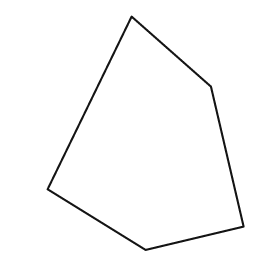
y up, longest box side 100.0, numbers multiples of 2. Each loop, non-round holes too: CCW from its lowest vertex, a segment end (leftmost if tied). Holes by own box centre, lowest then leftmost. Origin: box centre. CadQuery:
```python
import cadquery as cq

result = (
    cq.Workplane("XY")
    .moveTo(0.0, -50.0)
    .lineTo(42.0, -40.0)
    .lineTo(28.0, 20.0)
    .lineTo(-6.0, 50.0)
    .lineTo(-42.0, -24.0)
    .close()
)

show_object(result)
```